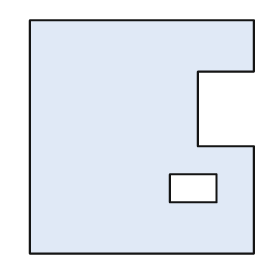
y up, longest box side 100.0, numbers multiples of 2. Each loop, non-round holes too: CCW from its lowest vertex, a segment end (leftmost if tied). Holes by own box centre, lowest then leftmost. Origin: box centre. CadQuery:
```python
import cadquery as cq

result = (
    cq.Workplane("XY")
    .moveTo(-48.0, -50.0)
    .lineTo(48.0, -50.0)
    .lineTo(48.0, -4.0)
    .lineTo(24.0, -4.0)
    .lineTo(24.0, 28.0)
    .lineTo(48.0, 28.0)
    .lineTo(48.0, 50.0)
    .lineTo(-48.0, 50.0)
    .close()
    .moveTo(12.0, -28.0)
    .lineTo(32.0, -28.0)
    .lineTo(32.0, -16.0)
    .lineTo(12.0, -16.0)
    .close()
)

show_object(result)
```